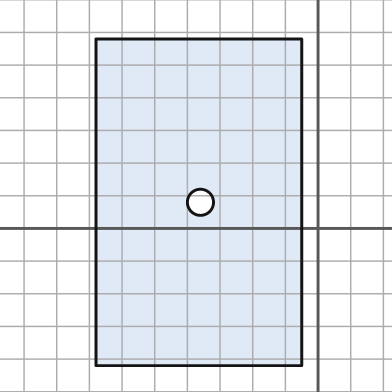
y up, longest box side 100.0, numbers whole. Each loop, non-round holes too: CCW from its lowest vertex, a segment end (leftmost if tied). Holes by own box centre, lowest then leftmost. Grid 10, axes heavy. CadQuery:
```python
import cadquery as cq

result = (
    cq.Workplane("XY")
    .moveTo(-68.0, -42.0)
    .lineTo(-5.0, -42.0)
    .lineTo(-5.0, 58.0)
    .lineTo(-68.0, 58.0)
    .close()
    .moveTo(-36.0, 8.0)
    .circle(4.0)
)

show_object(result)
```